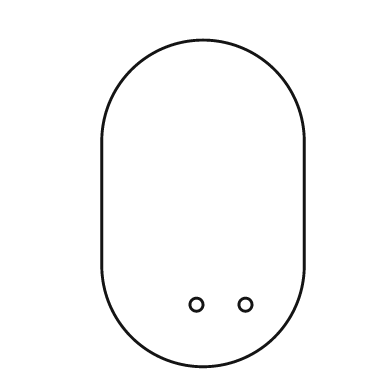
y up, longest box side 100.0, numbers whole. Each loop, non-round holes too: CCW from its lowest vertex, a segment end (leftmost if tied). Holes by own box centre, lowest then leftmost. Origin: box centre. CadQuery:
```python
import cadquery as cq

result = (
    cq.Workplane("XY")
    .moveTo(-31.0, -19.0)
    .threePointArc((0.0, -50.0), (31.0, -19.0))
    .lineTo(31.0, 19.0)
    .threePointArc((0.0, 50.0), (-31.0, 19.0))
    .close()
    .moveTo(-2.0, -31.0)
    .circle(2.0)
    .moveTo(13.0, -31.0)
    .circle(2.0)
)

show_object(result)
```